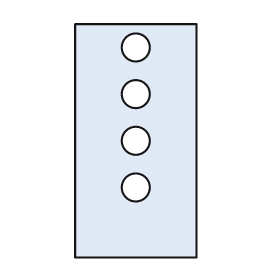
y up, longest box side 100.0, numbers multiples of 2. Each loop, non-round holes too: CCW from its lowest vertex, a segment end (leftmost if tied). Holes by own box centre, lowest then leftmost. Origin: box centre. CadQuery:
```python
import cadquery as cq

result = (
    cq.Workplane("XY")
    .moveTo(-26.0, -50.0)
    .lineTo(26.0, -50.0)
    .lineTo(26.0, 50.0)
    .lineTo(-26.0, 50.0)
    .close()
    .moveTo(0.0, -20.0)
    .circle(6.0)
    .moveTo(0.0, 0.0)
    .circle(6.0)
    .moveTo(0.0, 20.0)
    .circle(6.0)
    .moveTo(0.0, 40.0)
    .circle(6.0)
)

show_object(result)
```